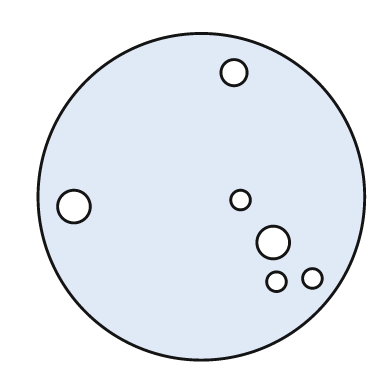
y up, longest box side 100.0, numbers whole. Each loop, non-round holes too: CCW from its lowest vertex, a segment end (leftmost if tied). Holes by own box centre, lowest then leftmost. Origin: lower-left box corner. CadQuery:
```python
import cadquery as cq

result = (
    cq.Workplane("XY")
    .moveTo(50.0, 50.0)
    .circle(50.0)
    .moveTo(73.0, 24.0)
    .circle(3.0)
    .moveTo(84.0, 25.0)
    .circle(3.0)
    .moveTo(72.0, 36.0)
    .circle(5.0)
    .moveTo(11.0, 47.0)
    .circle(5.0)
    .moveTo(62.0, 49.0)
    .circle(3.0)
    .moveTo(60.0, 88.0)
    .circle(4.0)
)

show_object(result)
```